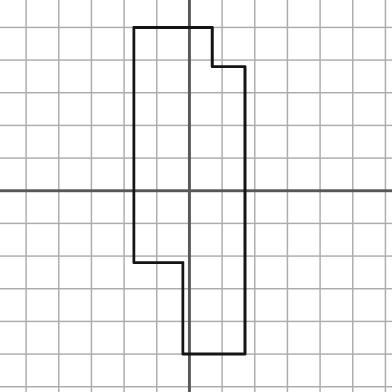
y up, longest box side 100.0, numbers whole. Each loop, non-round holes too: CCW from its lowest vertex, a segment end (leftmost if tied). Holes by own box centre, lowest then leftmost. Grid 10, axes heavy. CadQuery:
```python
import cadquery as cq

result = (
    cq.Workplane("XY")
    .moveTo(-2.0, -50.0)
    .lineTo(17.0, -50.0)
    .lineTo(17.0, 38.0)
    .lineTo(7.0, 38.0)
    .lineTo(7.0, 50.0)
    .lineTo(-17.0, 50.0)
    .lineTo(-17.0, -22.0)
    .lineTo(-2.0, -22.0)
    .close()
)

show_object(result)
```